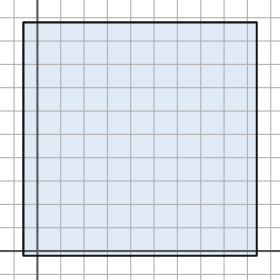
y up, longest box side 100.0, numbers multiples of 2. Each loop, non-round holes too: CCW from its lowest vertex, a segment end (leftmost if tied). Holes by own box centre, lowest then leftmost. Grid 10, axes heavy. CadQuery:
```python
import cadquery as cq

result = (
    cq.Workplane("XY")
    .moveTo(-6.0, -2.0)
    .lineTo(94.0, -2.0)
    .lineTo(94.0, 98.0)
    .lineTo(-6.0, 98.0)
    .close()
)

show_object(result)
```